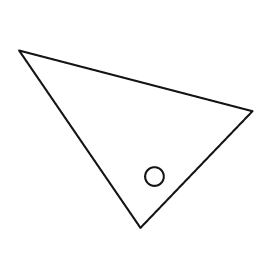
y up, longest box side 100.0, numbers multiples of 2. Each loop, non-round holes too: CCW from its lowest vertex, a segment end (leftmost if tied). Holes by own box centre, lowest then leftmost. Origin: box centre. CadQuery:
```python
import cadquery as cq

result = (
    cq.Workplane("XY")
    .moveTo(2.0, -38.0)
    .lineTo(50.0, 12.0)
    .lineTo(-50.0, 38.0)
    .close()
    .moveTo(8.0, -16.0)
    .circle(4.0)
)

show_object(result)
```